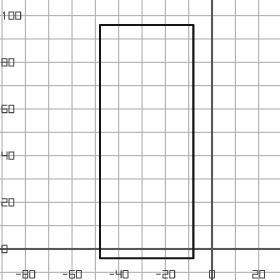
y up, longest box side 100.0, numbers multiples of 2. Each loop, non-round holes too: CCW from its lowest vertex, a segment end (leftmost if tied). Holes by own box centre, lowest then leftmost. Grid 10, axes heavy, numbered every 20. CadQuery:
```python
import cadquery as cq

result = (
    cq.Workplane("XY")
    .moveTo(-48.0, -4.0)
    .lineTo(-8.0, -4.0)
    .lineTo(-8.0, 96.0)
    .lineTo(-48.0, 96.0)
    .close()
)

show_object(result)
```